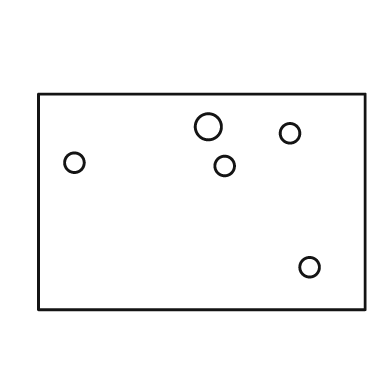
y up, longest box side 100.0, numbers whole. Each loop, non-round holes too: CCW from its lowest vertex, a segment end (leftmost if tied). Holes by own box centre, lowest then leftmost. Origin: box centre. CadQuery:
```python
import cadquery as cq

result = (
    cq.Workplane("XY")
    .moveTo(-50.0, -33.0)
    .lineTo(50.0, -33.0)
    .lineTo(50.0, 33.0)
    .lineTo(-50.0, 33.0)
    .close()
    .moveTo(33.0, -20.0)
    .circle(3.0)
    .moveTo(7.0, 11.0)
    .circle(3.0)
    .moveTo(-39.0, 12.0)
    .circle(3.0)
    .moveTo(27.0, 21.0)
    .circle(3.0)
    .moveTo(2.0, 23.0)
    .circle(4.0)
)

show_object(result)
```